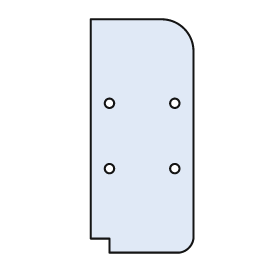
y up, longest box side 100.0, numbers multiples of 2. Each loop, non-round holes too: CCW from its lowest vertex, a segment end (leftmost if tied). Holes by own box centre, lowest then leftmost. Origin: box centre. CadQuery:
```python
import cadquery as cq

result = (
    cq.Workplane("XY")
    .moveTo(-14.0, -50.0)
    .lineTo(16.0, -50.0)
    .threePointArc((20.0, -48.0), (22.0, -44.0))
    .lineTo(22.0, 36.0)
    .threePointArc((18.0, 46.0), (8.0, 50.0))
    .lineTo(-22.0, 50.0)
    .lineTo(-22.0, -44.0)
    .lineTo(-14.0, -44.0)
    .close()
    .moveTo(-14.0, -14.0)
    .circle(2.0)
    .moveTo(14.0, -14.0)
    .circle(2.0)
    .moveTo(-14.0, 14.0)
    .circle(2.0)
    .moveTo(14.0, 14.0)
    .circle(2.0)
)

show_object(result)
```